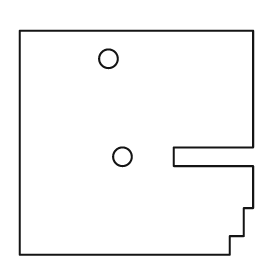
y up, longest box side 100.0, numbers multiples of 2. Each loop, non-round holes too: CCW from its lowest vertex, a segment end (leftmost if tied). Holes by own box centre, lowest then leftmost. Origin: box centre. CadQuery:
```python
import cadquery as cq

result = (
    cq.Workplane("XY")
    .moveTo(-50.0, -48.0)
    .lineTo(40.0, -48.0)
    .lineTo(40.0, -40.0)
    .lineTo(46.0, -40.0)
    .lineTo(46.0, -28.0)
    .lineTo(50.0, -28.0)
    .lineTo(50.0, -10.0)
    .lineTo(16.0, -10.0)
    .lineTo(16.0, -2.0)
    .lineTo(50.0, -2.0)
    .lineTo(50.0, 48.0)
    .lineTo(-50.0, 48.0)
    .close()
    .moveTo(-6.0, -6.0)
    .circle(4.0)
    .moveTo(-12.0, 36.0)
    .circle(4.0)
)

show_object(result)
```